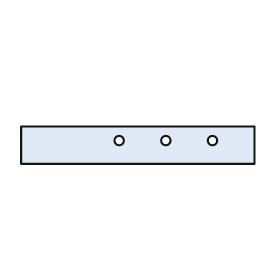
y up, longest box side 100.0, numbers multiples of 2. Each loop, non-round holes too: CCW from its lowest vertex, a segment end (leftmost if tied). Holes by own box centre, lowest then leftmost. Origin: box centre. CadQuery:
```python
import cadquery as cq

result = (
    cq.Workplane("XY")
    .moveTo(-50.0, -8.0)
    .lineTo(50.0, -8.0)
    .lineTo(50.0, 8.0)
    .lineTo(-50.0, 8.0)
    .close()
    .moveTo(-8.0, 2.0)
    .circle(2.0)
    .moveTo(12.0, 2.0)
    .circle(2.0)
    .moveTo(32.0, 2.0)
    .circle(2.0)
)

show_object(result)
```